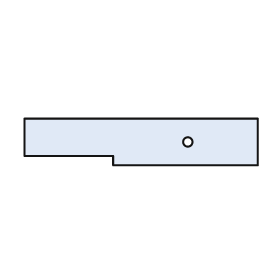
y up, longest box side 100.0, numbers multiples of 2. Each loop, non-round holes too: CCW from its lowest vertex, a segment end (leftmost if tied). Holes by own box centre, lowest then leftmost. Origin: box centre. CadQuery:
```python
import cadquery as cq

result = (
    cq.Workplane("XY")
    .moveTo(-12.0, -10.0)
    .lineTo(50.0, -10.0)
    .lineTo(50.0, 10.0)
    .lineTo(-50.0, 10.0)
    .lineTo(-50.0, -6.0)
    .lineTo(-12.0, -6.0)
    .close()
    .moveTo(20.0, 0.0)
    .circle(2.0)
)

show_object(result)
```